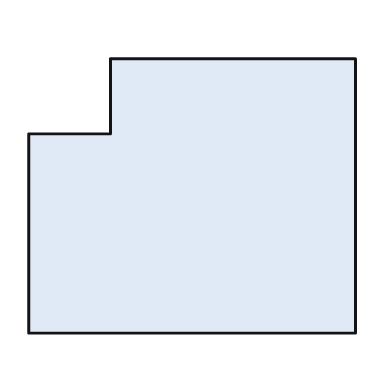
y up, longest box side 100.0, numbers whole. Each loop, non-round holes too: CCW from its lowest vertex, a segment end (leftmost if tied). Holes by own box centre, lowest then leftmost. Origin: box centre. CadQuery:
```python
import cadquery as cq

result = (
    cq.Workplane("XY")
    .moveTo(-50.0, -42.0)
    .lineTo(50.0, -42.0)
    .lineTo(50.0, 42.0)
    .lineTo(-25.0, 42.0)
    .lineTo(-25.0, 19.0)
    .lineTo(-50.0, 19.0)
    .close()
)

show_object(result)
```